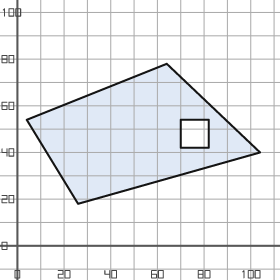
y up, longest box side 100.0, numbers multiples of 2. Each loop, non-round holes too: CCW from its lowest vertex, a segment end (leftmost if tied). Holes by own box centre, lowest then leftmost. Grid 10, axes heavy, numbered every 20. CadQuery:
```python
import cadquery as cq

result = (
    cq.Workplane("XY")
    .moveTo(26.0, 18.0)
    .lineTo(104.0, 40.0)
    .lineTo(64.0, 78.0)
    .lineTo(4.0, 54.0)
    .close()
    .moveTo(70.0, 42.0)
    .lineTo(82.0, 42.0)
    .lineTo(82.0, 54.0)
    .lineTo(70.0, 54.0)
    .close()
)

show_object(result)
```